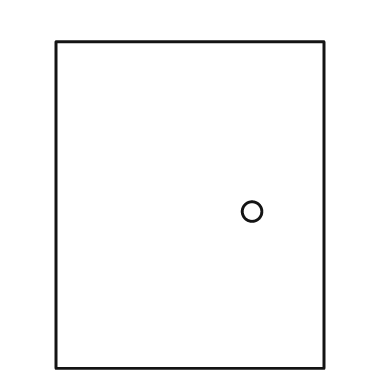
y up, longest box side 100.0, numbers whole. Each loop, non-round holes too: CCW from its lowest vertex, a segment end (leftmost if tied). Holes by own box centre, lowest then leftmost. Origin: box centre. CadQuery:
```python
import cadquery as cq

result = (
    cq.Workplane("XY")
    .moveTo(-41.0, -50.0)
    .lineTo(41.0, -50.0)
    .lineTo(41.0, 50.0)
    .lineTo(-41.0, 50.0)
    .close()
    .moveTo(19.0, -2.0)
    .circle(3.0)
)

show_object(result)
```